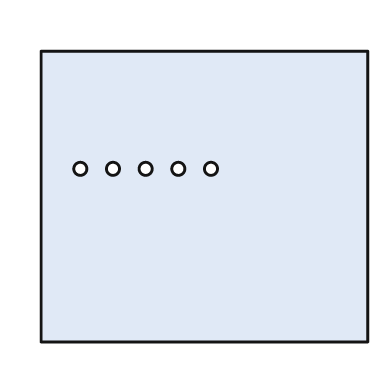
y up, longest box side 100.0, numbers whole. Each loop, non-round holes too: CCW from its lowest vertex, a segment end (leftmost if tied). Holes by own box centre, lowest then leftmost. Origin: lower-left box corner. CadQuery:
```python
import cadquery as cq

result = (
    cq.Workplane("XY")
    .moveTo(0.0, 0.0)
    .lineTo(100.0, 0.0)
    .lineTo(100.0, 89.0)
    .lineTo(0.0, 89.0)
    .close()
    .moveTo(12.0, 53.0)
    .circle(2.0)
    .moveTo(22.0, 53.0)
    .circle(2.0)
    .moveTo(32.0, 53.0)
    .circle(2.0)
    .moveTo(42.0, 53.0)
    .circle(2.0)
    .moveTo(52.0, 53.0)
    .circle(2.0)
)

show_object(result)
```